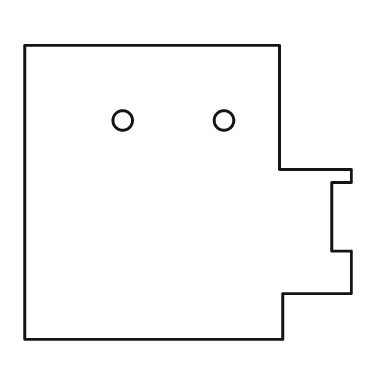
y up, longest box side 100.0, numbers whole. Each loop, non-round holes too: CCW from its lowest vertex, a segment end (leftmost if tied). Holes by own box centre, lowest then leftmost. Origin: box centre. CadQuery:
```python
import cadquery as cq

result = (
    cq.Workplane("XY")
    .moveTo(-50.0, -45.0)
    .lineTo(29.0, -45.0)
    .lineTo(29.0, -31.0)
    .lineTo(50.0, -31.0)
    .lineTo(50.0, -18.0)
    .lineTo(44.0, -18.0)
    .lineTo(44.0, 3.0)
    .lineTo(50.0, 3.0)
    .lineTo(50.0, 7.0)
    .lineTo(28.0, 7.0)
    .lineTo(28.0, 45.0)
    .lineTo(-50.0, 45.0)
    .close()
    .moveTo(-20.0, 22.0)
    .circle(3.0)
    .moveTo(11.0, 22.0)
    .circle(3.0)
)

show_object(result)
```